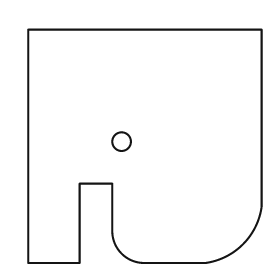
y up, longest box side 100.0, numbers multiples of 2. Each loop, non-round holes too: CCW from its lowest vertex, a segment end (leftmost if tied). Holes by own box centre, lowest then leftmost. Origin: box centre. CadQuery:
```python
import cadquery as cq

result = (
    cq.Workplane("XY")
    .moveTo(-50.0, -50.0)
    .lineTo(-28.0, -50.0)
    .lineTo(-28.0, -16.0)
    .lineTo(-14.0, -16.0)
    .lineTo(-14.0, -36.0)
    .threePointArc((-10.0, -46.0), (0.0, -50.0))
    .lineTo(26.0, -50.0)
    .threePointArc((42.0, -42.0), (50.0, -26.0))
    .lineTo(50.0, 50.0)
    .lineTo(-50.0, 50.0)
    .close()
    .moveTo(-10.0, 2.0)
    .circle(4.0)
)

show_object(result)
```